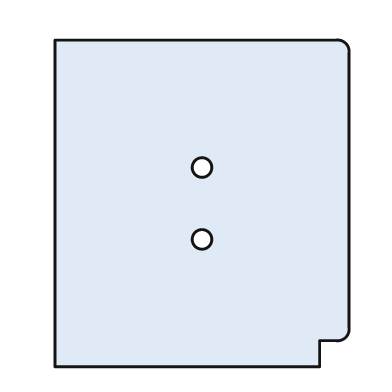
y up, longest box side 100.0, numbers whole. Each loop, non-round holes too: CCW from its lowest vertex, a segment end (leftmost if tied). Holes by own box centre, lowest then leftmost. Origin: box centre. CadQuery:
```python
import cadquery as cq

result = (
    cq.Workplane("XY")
    .moveTo(-45.0, -50.0)
    .lineTo(36.0, -50.0)
    .lineTo(36.0, -42.0)
    .lineTo(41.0, -42.0)
    .threePointArc((44.0, -41.0), (45.0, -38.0))
    .lineTo(45.0, 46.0)
    .threePointArc((44.0, 49.0), (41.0, 50.0))
    .lineTo(-45.0, 50.0)
    .close()
    .moveTo(0.0, -11.0)
    .circle(3.0)
    .moveTo(0.0, 11.0)
    .circle(3.0)
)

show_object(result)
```